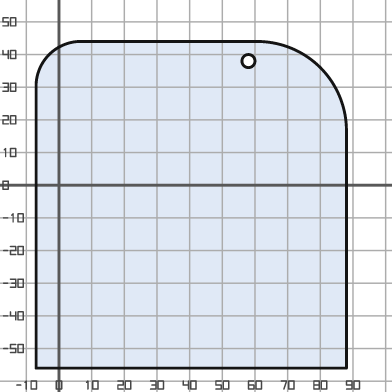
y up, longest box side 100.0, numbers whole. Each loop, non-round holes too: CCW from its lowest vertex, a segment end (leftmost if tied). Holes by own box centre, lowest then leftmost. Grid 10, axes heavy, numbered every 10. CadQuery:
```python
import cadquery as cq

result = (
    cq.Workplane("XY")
    .moveTo(-7.0, -56.0)
    .lineTo(88.0, -56.0)
    .lineTo(88.0, 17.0)
    .threePointArc((80.0, 36.0), (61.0, 44.0))
    .lineTo(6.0, 44.0)
    .threePointArc((-3.0, 40.0), (-7.0, 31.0))
    .close()
    .moveTo(58.0, 38.0)
    .circle(2.0)
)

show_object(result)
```